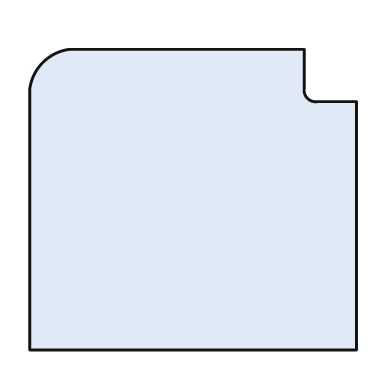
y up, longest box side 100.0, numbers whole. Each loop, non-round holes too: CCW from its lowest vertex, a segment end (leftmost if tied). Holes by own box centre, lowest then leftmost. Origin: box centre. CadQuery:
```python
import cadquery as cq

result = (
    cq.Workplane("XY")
    .moveTo(-50.0, -46.0)
    .lineTo(50.0, -46.0)
    .lineTo(50.0, 30.0)
    .lineTo(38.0, 30.0)
    .threePointArc((35.0, 31.0), (34.0, 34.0))
    .lineTo(34.0, 46.0)
    .lineTo(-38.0, 46.0)
    .threePointArc((-46.0, 42.0), (-50.0, 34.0))
    .close()
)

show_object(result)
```